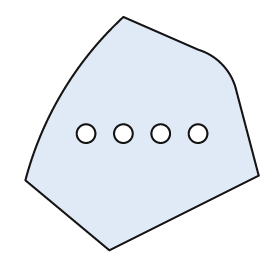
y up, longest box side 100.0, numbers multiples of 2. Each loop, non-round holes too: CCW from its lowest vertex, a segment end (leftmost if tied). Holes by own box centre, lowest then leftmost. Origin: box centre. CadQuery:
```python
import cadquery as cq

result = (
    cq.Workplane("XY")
    .moveTo(-14.0, -50.0)
    .lineTo(50.0, -18.0)
    .lineTo(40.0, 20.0)
    .threePointArc((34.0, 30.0), (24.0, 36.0))
    .lineTo(-8.0, 50.0)
    .threePointArc((-34.0, 18.0), (-50.0, -20.0))
    .close()
    .moveTo(-24.0, 0.0)
    .circle(4.0)
    .moveTo(-8.0, 0.0)
    .circle(4.0)
    .moveTo(8.0, 0.0)
    .circle(4.0)
    .moveTo(24.0, 0.0)
    .circle(4.0)
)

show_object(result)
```